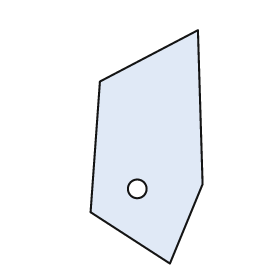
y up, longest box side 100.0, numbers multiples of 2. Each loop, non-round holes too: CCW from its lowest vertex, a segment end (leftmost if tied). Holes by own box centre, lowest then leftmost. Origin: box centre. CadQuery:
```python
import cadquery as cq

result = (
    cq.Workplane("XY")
    .moveTo(10.0, -50.0)
    .lineTo(24.0, -16.0)
    .lineTo(22.0, 50.0)
    .lineTo(-20.0, 28.0)
    .lineTo(-24.0, -28.0)
    .close()
    .moveTo(-4.0, -18.0)
    .circle(4.0)
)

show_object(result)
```